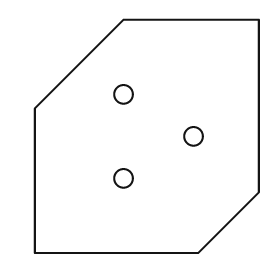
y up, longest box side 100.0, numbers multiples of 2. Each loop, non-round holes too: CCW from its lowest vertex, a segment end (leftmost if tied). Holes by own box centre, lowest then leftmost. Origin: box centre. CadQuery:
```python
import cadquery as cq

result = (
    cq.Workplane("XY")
    .moveTo(-48.0, -50.0)
    .lineTo(22.0, -50.0)
    .lineTo(48.0, -24.0)
    .lineTo(48.0, 50.0)
    .lineTo(-10.0, 50.0)
    .lineTo(-48.0, 12.0)
    .close()
    .moveTo(-10.0, -18.0)
    .circle(4.0)
    .moveTo(20.0, 0.0)
    .circle(4.0)
    .moveTo(-10.0, 18.0)
    .circle(4.0)
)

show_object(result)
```